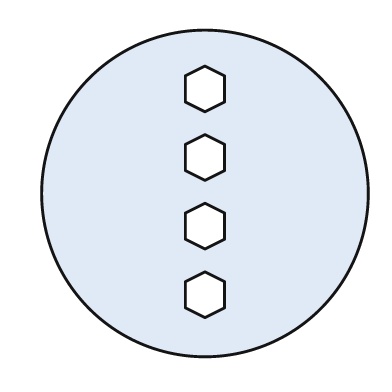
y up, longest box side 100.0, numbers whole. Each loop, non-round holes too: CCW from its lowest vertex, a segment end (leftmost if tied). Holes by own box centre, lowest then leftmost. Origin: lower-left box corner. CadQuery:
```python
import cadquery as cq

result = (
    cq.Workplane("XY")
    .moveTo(50.0, 50.0)
    .circle(50.0)
    .moveTo(50.0, 12.0)
    .lineTo(56.0, 15.0)
    .lineTo(56.0, 23.0)
    .lineTo(50.0, 26.0)
    .lineTo(44.0, 23.0)
    .lineTo(44.0, 15.0)
    .close()
    .moveTo(50.0, 33.0)
    .lineTo(56.0, 36.0)
    .lineTo(56.0, 44.0)
    .lineTo(50.0, 47.0)
    .lineTo(44.0, 44.0)
    .lineTo(44.0, 36.0)
    .close()
    .moveTo(50.0, 54.0)
    .lineTo(56.0, 57.0)
    .lineTo(56.0, 65.0)
    .lineTo(50.0, 68.0)
    .lineTo(44.0, 65.0)
    .lineTo(44.0, 57.0)
    .close()
    .moveTo(50.0, 75.0)
    .lineTo(56.0, 78.0)
    .lineTo(56.0, 86.0)
    .lineTo(50.0, 89.0)
    .lineTo(44.0, 86.0)
    .lineTo(44.0, 78.0)
    .close()
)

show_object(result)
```